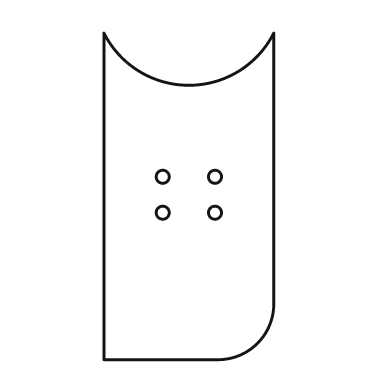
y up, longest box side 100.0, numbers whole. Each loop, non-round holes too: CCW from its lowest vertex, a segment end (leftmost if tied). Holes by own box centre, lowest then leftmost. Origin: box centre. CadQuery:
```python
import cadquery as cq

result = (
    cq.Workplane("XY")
    .moveTo(-26.0, -50.0)
    .lineTo(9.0, -50.0)
    .threePointArc((21.0, -45.0), (26.0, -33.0))
    .lineTo(26.0, 50.0)
    .threePointArc((0.0, 34.0), (-26.0, 50.0))
    .close()
    .moveTo(-8.0, -5.0)
    .circle(2.0)
    .moveTo(8.0, -5.0)
    .circle(2.0)
    .moveTo(-8.0, 6.0)
    .circle(2.0)
    .moveTo(8.0, 6.0)
    .circle(2.0)
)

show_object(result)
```